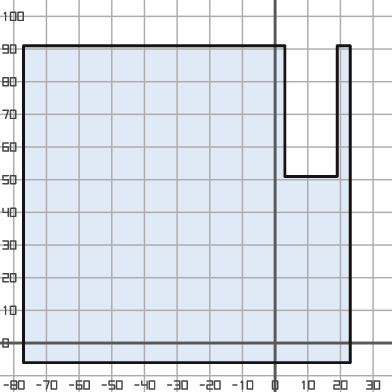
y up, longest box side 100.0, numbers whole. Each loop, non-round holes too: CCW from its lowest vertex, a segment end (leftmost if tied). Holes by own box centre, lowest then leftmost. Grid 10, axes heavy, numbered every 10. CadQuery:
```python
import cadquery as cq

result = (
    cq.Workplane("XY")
    .moveTo(-77.0, -6.0)
    .lineTo(23.0, -6.0)
    .lineTo(23.0, 91.0)
    .lineTo(19.0, 91.0)
    .lineTo(19.0, 51.0)
    .lineTo(3.0, 51.0)
    .lineTo(3.0, 91.0)
    .lineTo(-77.0, 91.0)
    .close()
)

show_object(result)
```